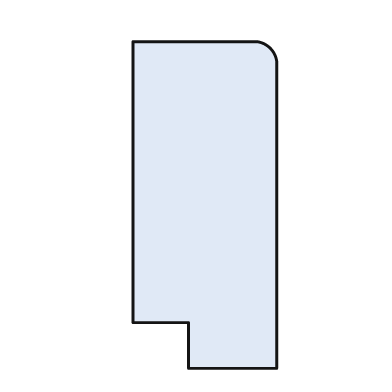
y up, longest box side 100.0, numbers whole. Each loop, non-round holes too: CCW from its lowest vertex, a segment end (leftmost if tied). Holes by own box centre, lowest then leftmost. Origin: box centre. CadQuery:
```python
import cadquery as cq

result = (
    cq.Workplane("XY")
    .moveTo(-5.0, -50.0)
    .lineTo(22.0, -50.0)
    .lineTo(22.0, 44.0)
    .threePointArc((20.0, 48.0), (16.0, 50.0))
    .lineTo(-22.0, 50.0)
    .lineTo(-22.0, -36.0)
    .lineTo(-5.0, -36.0)
    .close()
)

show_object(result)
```